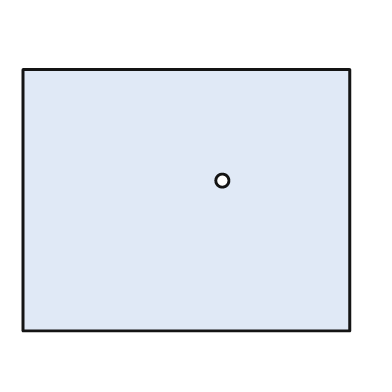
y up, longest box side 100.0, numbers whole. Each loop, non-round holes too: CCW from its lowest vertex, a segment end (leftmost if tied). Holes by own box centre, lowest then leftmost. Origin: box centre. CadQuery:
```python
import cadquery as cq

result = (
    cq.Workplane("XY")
    .moveTo(-50.0, -40.0)
    .lineTo(50.0, -40.0)
    .lineTo(50.0, 40.0)
    .lineTo(-50.0, 40.0)
    .close()
    .moveTo(11.0, 6.0)
    .circle(2.0)
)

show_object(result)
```